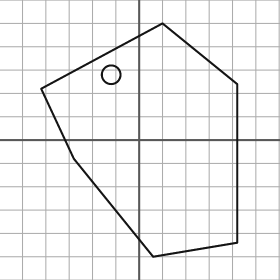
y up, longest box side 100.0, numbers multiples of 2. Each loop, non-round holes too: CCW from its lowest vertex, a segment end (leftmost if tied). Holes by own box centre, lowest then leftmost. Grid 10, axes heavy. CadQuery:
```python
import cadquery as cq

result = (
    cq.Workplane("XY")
    .moveTo(6.0, -50.0)
    .lineTo(42.0, -44.0)
    .lineTo(42.0, 24.0)
    .lineTo(10.0, 50.0)
    .lineTo(-42.0, 22.0)
    .lineTo(-28.0, -8.0)
    .close()
    .moveTo(-12.0, 28.0)
    .circle(4.0)
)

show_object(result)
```